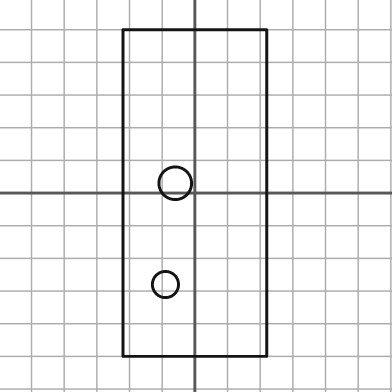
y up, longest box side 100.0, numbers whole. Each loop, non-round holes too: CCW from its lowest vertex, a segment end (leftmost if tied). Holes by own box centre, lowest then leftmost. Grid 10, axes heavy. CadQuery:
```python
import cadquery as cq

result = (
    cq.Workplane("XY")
    .moveTo(-22.0, -50.0)
    .lineTo(22.0, -50.0)
    .lineTo(22.0, 50.0)
    .lineTo(-22.0, 50.0)
    .close()
    .moveTo(-9.0, -28.0)
    .circle(4.0)
    .moveTo(-6.0, 3.0)
    .circle(5.0)
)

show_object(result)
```